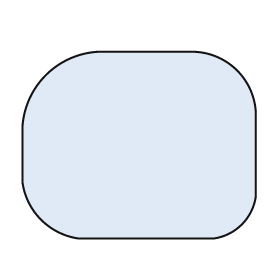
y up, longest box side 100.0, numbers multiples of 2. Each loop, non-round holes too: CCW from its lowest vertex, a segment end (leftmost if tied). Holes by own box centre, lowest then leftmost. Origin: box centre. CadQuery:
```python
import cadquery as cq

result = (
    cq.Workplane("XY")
    .moveTo(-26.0, -40.0)
    .lineTo(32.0, -40.0)
    .threePointArc((44.0, -34.0), (50.0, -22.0))
    .lineTo(50.0, 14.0)
    .threePointArc((42.0, 32.0), (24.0, 40.0))
    .lineTo(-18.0, 40.0)
    .threePointArc((-40.0, 30.0), (-50.0, 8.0))
    .lineTo(-50.0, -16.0)
    .threePointArc((-42.0, -32.0), (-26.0, -40.0))
    .close()
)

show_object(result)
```